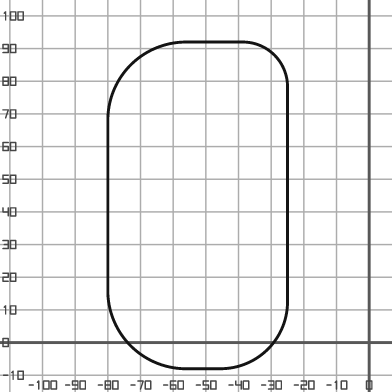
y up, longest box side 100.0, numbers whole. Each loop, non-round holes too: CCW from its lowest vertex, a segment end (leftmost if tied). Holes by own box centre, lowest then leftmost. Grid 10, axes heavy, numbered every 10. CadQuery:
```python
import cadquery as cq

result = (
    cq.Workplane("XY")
    .moveTo(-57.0, -8.0)
    .lineTo(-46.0, -8.0)
    .threePointArc((-31.0, -2.0), (-25.0, 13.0))
    .lineTo(-25.0, 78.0)
    .threePointArc((-29.0, 88.0), (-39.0, 92.0))
    .lineTo(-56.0, 92.0)
    .threePointArc((-73.0, 85.0), (-80.0, 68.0))
    .lineTo(-80.0, 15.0)
    .threePointArc((-73.0, -1.0), (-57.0, -8.0))
    .close()
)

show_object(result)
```